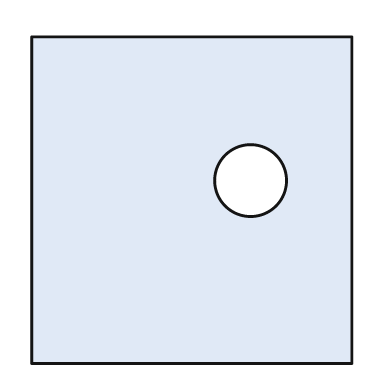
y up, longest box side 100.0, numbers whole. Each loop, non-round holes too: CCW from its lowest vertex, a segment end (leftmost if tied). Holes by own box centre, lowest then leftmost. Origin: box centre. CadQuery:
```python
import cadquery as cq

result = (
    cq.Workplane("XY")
    .moveTo(-49.0, -50.0)
    .lineTo(49.0, -50.0)
    .lineTo(49.0, 50.0)
    .lineTo(-49.0, 50.0)
    .close()
    .moveTo(18.0, 6.0)
    .circle(11.0)
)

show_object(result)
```